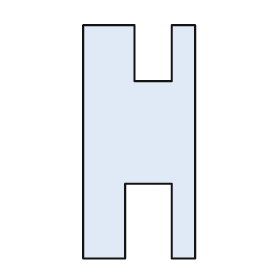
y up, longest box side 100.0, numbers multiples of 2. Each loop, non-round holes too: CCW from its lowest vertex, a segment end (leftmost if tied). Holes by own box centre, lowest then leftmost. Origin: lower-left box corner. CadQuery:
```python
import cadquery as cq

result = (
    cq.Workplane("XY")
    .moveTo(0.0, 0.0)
    .lineTo(18.0, 0.0)
    .lineTo(18.0, 32.0)
    .lineTo(38.0, 32.0)
    .lineTo(38.0, 0.0)
    .lineTo(48.0, 0.0)
    .lineTo(48.0, 100.0)
    .lineTo(38.0, 100.0)
    .lineTo(38.0, 76.0)
    .lineTo(22.0, 76.0)
    .lineTo(22.0, 100.0)
    .lineTo(0.0, 100.0)
    .close()
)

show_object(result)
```